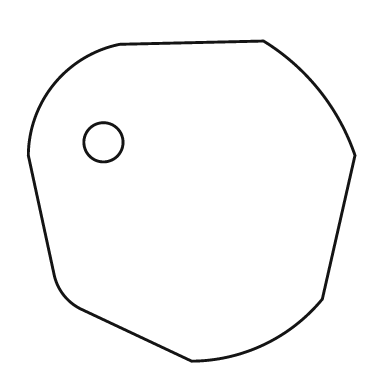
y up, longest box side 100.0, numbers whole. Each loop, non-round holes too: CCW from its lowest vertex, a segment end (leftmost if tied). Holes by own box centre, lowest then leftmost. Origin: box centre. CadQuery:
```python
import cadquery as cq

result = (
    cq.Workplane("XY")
    .moveTo(0.0, -49.0)
    .threePointArc((22.0, -44.0), (40.0, -30.0))
    .lineTo(50.0, 14.0)
    .threePointArc((39.0, 34.0), (22.0, 49.0))
    .lineTo(-22.0, 48.0)
    .threePointArc((-42.0, 36.0), (-50.0, 14.0))
    .lineTo(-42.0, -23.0)
    .threePointArc((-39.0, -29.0), (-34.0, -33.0))
    .close()
    .moveTo(-27.0, 18.0)
    .circle(6.0)
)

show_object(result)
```